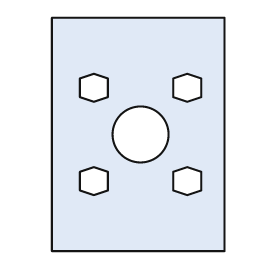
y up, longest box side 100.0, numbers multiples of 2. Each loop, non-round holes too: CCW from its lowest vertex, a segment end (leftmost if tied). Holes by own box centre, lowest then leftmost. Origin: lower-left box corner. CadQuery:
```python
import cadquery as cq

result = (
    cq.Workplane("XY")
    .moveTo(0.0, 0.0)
    .lineTo(74.0, 0.0)
    .lineTo(74.0, 100.0)
    .lineTo(0.0, 100.0)
    .close()
    .moveTo(18.0, 24.0)
    .lineTo(24.0, 26.0)
    .lineTo(24.0, 34.0)
    .lineTo(18.0, 36.0)
    .lineTo(12.0, 34.0)
    .lineTo(12.0, 26.0)
    .close()
    .moveTo(58.0, 24.0)
    .lineTo(64.0, 26.0)
    .lineTo(64.0, 34.0)
    .lineTo(58.0, 36.0)
    .lineTo(52.0, 34.0)
    .lineTo(52.0, 26.0)
    .close()
    .moveTo(38.0, 50.0)
    .circle(12.0)
    .moveTo(18.0, 64.0)
    .lineTo(24.0, 66.0)
    .lineTo(24.0, 74.0)
    .lineTo(18.0, 76.0)
    .lineTo(12.0, 74.0)
    .lineTo(12.0, 66.0)
    .close()
    .moveTo(58.0, 64.0)
    .lineTo(64.0, 66.0)
    .lineTo(64.0, 74.0)
    .lineTo(58.0, 76.0)
    .lineTo(52.0, 74.0)
    .lineTo(52.0, 66.0)
    .close()
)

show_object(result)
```